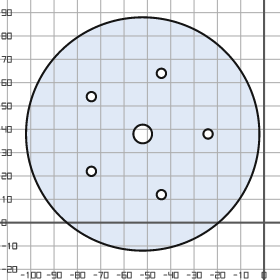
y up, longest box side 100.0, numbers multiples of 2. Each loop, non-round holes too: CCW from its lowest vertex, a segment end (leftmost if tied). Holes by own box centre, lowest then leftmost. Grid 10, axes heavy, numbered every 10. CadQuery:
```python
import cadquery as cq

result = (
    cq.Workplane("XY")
    .moveTo(-52.0, 38.0)
    .circle(50.0)
    .moveTo(-44.0, 12.0)
    .circle(2.0)
    .moveTo(-74.0, 22.0)
    .circle(2.0)
    .moveTo(-52.0, 38.0)
    .circle(4.0)
    .moveTo(-24.0, 38.0)
    .circle(2.0)
    .moveTo(-74.0, 54.0)
    .circle(2.0)
    .moveTo(-44.0, 64.0)
    .circle(2.0)
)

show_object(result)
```